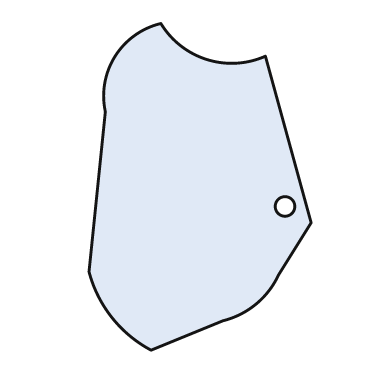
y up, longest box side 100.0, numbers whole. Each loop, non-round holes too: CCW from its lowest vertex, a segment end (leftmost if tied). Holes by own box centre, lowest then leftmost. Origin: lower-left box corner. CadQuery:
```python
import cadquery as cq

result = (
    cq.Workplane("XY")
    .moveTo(19.0, 0.0)
    .lineTo(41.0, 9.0)
    .threePointArc((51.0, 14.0), (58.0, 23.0))
    .lineTo(68.0, 39.0)
    .lineTo(54.0, 90.0)
    .threePointArc((36.0, 89.0), (22.0, 100.0))
    .threePointArc((8.0, 90.0), (5.0, 73.0))
    .lineTo(0.0, 24.0)
    .threePointArc((7.0, 10.0), (19.0, 0.0))
    .close()
    .moveTo(60.0, 44.0)
    .circle(3.0)
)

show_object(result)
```